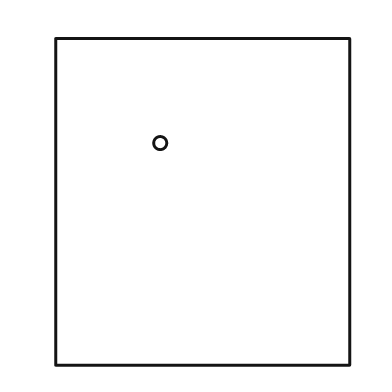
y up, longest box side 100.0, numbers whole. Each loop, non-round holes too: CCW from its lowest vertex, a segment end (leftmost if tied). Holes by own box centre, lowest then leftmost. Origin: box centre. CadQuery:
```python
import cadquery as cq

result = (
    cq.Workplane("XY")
    .moveTo(-45.0, -50.0)
    .lineTo(45.0, -50.0)
    .lineTo(45.0, 50.0)
    .lineTo(-45.0, 50.0)
    .close()
    .moveTo(-13.0, 18.0)
    .circle(2.0)
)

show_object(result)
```